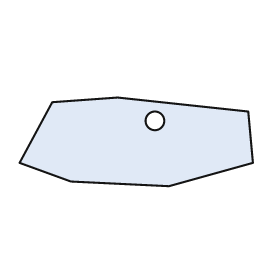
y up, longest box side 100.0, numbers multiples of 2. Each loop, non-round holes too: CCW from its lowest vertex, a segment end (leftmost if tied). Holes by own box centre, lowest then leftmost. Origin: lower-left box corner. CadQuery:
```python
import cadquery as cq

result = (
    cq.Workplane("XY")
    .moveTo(64.0, 0.0)
    .lineTo(100.0, 10.0)
    .lineTo(98.0, 32.0)
    .lineTo(42.0, 38.0)
    .lineTo(14.0, 36.0)
    .lineTo(0.0, 10.0)
    .lineTo(22.0, 2.0)
    .close()
    .moveTo(58.0, 28.0)
    .circle(4.0)
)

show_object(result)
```